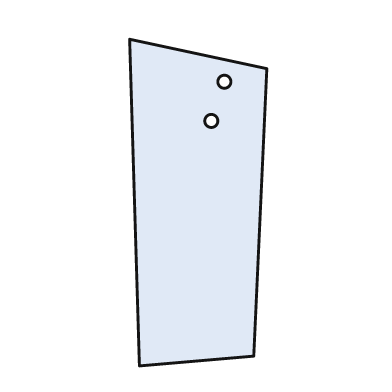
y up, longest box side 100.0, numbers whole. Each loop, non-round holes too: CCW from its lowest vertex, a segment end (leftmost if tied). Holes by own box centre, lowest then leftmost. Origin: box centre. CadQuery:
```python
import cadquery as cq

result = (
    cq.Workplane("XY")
    .moveTo(-18.0, -50.0)
    .lineTo(17.0, -47.0)
    .lineTo(21.0, 41.0)
    .lineTo(-21.0, 50.0)
    .close()
    .moveTo(4.0, 25.0)
    .circle(2.0)
    .moveTo(8.0, 37.0)
    .circle(2.0)
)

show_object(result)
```